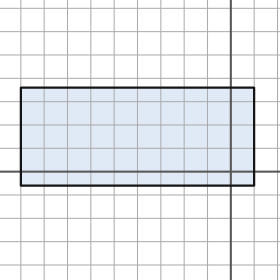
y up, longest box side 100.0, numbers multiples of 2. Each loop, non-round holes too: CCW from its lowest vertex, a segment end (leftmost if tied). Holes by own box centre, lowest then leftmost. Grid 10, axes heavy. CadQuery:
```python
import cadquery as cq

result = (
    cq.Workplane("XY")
    .moveTo(-90.0, -6.0)
    .lineTo(10.0, -6.0)
    .lineTo(10.0, 36.0)
    .lineTo(-90.0, 36.0)
    .close()
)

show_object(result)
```